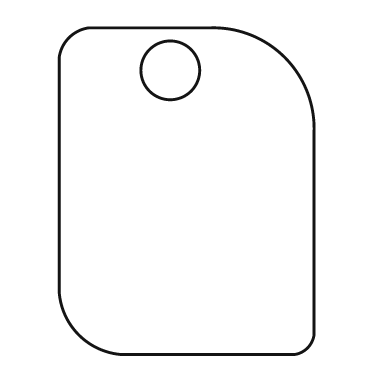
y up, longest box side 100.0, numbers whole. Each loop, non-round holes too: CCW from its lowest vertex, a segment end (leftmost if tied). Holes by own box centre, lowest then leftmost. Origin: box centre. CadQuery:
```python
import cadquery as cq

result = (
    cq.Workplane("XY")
    .moveTo(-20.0, -50.0)
    .lineTo(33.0, -50.0)
    .threePointArc((37.0, -48.0), (39.0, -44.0))
    .lineTo(39.0, 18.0)
    .threePointArc((30.0, 41.0), (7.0, 50.0))
    .lineTo(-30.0, 50.0)
    .threePointArc((-36.0, 47.0), (-39.0, 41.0))
    .lineTo(-39.0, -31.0)
    .threePointArc((-33.0, -44.0), (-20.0, -50.0))
    .close()
    .moveTo(-5.0, 37.0)
    .circle(9.0)
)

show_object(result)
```